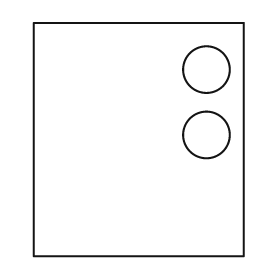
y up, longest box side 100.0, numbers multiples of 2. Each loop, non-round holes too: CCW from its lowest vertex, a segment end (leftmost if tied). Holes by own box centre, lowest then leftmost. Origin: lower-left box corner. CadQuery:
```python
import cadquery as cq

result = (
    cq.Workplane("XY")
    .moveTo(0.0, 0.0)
    .lineTo(90.0, 0.0)
    .lineTo(90.0, 100.0)
    .lineTo(0.0, 100.0)
    .close()
    .moveTo(74.0, 52.0)
    .circle(10.0)
    .moveTo(74.0, 80.0)
    .circle(10.0)
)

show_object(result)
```